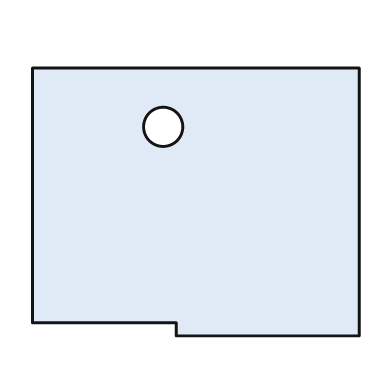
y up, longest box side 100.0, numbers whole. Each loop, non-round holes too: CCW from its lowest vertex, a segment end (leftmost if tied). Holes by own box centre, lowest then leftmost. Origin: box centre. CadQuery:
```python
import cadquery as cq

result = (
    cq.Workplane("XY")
    .moveTo(-6.0, -41.0)
    .lineTo(50.0, -41.0)
    .lineTo(50.0, 41.0)
    .lineTo(-50.0, 41.0)
    .lineTo(-50.0, -37.0)
    .lineTo(-6.0, -37.0)
    .close()
    .moveTo(-10.0, 23.0)
    .circle(6.0)
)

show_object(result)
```